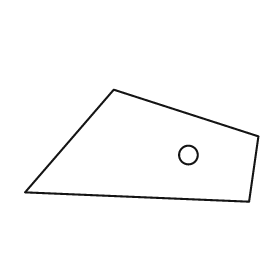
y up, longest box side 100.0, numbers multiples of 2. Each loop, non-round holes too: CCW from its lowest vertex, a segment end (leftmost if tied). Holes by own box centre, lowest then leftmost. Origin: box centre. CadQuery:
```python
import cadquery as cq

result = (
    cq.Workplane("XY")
    .moveTo(46.0, -24.0)
    .lineTo(50.0, 4.0)
    .lineTo(-12.0, 24.0)
    .lineTo(-50.0, -20.0)
    .close()
    .moveTo(20.0, -4.0)
    .circle(4.0)
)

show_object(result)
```